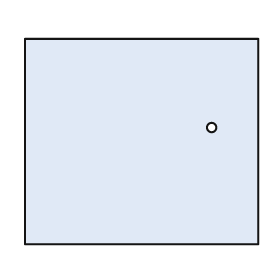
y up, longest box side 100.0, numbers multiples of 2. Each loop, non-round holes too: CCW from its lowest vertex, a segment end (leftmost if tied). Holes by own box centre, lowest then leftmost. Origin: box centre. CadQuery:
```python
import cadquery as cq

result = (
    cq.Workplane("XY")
    .moveTo(-50.0, -44.0)
    .lineTo(50.0, -44.0)
    .lineTo(50.0, 44.0)
    .lineTo(-50.0, 44.0)
    .close()
    .moveTo(30.0, 6.0)
    .circle(2.0)
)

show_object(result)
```